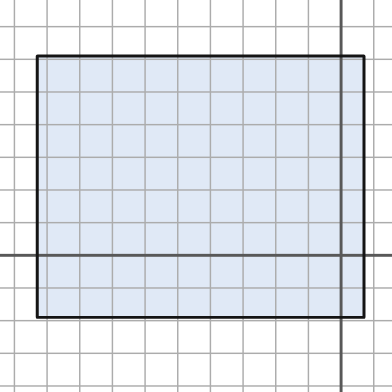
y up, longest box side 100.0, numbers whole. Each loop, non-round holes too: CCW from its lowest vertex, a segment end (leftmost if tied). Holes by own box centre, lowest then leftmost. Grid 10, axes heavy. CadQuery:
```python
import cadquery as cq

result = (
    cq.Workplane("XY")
    .moveTo(-93.0, -19.0)
    .lineTo(7.0, -19.0)
    .lineTo(7.0, 61.0)
    .lineTo(-93.0, 61.0)
    .close()
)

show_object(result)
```